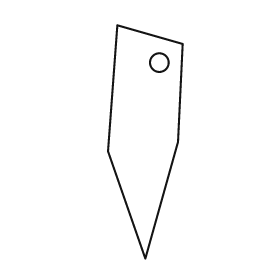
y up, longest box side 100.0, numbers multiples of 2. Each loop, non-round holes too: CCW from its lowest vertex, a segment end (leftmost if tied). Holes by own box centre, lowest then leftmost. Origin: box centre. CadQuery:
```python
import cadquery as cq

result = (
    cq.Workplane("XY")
    .moveTo(0.0, -50.0)
    .lineTo(14.0, 0.0)
    .lineTo(16.0, 42.0)
    .lineTo(-12.0, 50.0)
    .lineTo(-16.0, -4.0)
    .close()
    .moveTo(6.0, 34.0)
    .circle(4.0)
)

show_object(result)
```